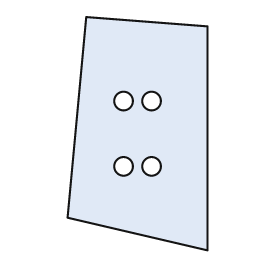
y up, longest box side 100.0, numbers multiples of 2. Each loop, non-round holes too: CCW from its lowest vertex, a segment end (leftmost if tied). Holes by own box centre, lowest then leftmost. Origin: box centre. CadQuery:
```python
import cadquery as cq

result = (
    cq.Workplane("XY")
    .moveTo(30.0, -50.0)
    .lineTo(30.0, 46.0)
    .lineTo(-22.0, 50.0)
    .lineTo(-30.0, -36.0)
    .close()
    .moveTo(-6.0, -14.0)
    .circle(4.0)
    .moveTo(6.0, -14.0)
    .circle(4.0)
    .moveTo(-6.0, 14.0)
    .circle(4.0)
    .moveTo(6.0, 14.0)
    .circle(4.0)
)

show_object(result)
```